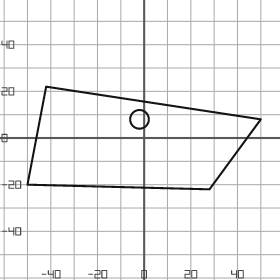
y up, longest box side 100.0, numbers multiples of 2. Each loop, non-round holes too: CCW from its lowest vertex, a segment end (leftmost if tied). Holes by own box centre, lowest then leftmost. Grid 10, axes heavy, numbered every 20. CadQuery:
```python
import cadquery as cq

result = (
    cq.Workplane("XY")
    .moveTo(28.0, -22.0)
    .lineTo(50.0, 8.0)
    .lineTo(-42.0, 22.0)
    .lineTo(-50.0, -20.0)
    .close()
    .moveTo(-2.0, 8.0)
    .circle(4.0)
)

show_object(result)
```